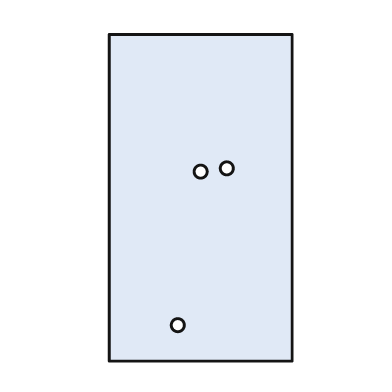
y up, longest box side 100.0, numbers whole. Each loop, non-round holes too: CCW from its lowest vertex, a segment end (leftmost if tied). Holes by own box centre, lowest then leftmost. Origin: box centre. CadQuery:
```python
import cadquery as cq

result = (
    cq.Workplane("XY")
    .moveTo(-28.0, -50.0)
    .lineTo(28.0, -50.0)
    .lineTo(28.0, 50.0)
    .lineTo(-28.0, 50.0)
    .close()
    .moveTo(-7.0, -39.0)
    .circle(2.0)
    .moveTo(0.0, 8.0)
    .circle(2.0)
    .moveTo(8.0, 9.0)
    .circle(2.0)
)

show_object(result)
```